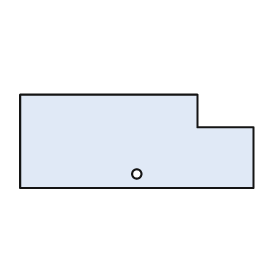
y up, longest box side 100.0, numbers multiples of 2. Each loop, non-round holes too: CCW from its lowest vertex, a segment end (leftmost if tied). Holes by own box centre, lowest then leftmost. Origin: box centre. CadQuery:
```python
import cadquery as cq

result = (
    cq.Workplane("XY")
    .moveTo(-50.0, -20.0)
    .lineTo(50.0, -20.0)
    .lineTo(50.0, 6.0)
    .lineTo(26.0, 6.0)
    .lineTo(26.0, 20.0)
    .lineTo(-50.0, 20.0)
    .close()
    .moveTo(0.0, -14.0)
    .circle(2.0)
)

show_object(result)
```